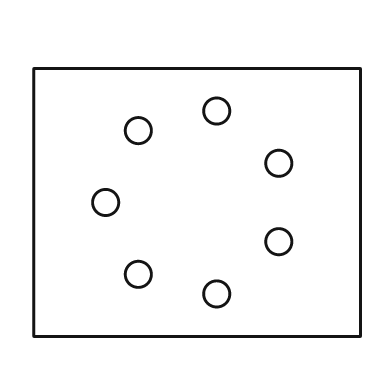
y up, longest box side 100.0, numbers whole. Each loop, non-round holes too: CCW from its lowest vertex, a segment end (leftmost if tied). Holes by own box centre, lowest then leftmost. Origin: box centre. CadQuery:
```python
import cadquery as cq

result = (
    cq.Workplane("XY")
    .moveTo(-50.0, -41.0)
    .lineTo(50.0, -41.0)
    .lineTo(50.0, 41.0)
    .lineTo(-50.0, 41.0)
    .close()
    .moveTo(6.0, -28.0)
    .circle(4.0)
    .moveTo(-18.0, -22.0)
    .circle(4.0)
    .moveTo(25.0, -12.0)
    .circle(4.0)
    .moveTo(-28.0, 0.0)
    .circle(4.0)
    .moveTo(25.0, 12.0)
    .circle(4.0)
    .moveTo(-18.0, 22.0)
    .circle(4.0)
    .moveTo(6.0, 28.0)
    .circle(4.0)
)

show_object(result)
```